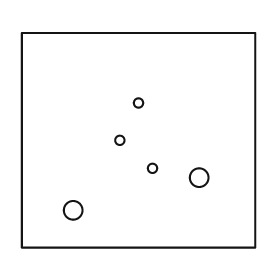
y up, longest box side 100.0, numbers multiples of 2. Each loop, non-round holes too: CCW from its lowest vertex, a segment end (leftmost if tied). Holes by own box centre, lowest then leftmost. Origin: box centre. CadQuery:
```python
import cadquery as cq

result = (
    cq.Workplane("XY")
    .moveTo(-50.0, -46.0)
    .lineTo(50.0, -46.0)
    .lineTo(50.0, 46.0)
    .lineTo(-50.0, 46.0)
    .close()
    .moveTo(-28.0, -30.0)
    .circle(4.0)
    .moveTo(26.0, -16.0)
    .circle(4.0)
    .moveTo(6.0, -12.0)
    .circle(2.0)
    .moveTo(-8.0, 0.0)
    .circle(2.0)
    .moveTo(0.0, 16.0)
    .circle(2.0)
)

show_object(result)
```